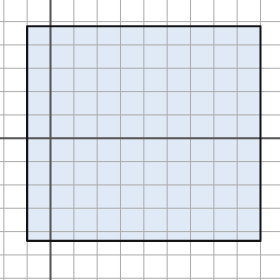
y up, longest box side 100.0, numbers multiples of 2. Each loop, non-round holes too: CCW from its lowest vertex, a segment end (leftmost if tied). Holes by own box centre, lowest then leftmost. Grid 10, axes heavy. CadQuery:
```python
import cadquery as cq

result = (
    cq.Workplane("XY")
    .moveTo(-10.0, -44.0)
    .lineTo(90.0, -44.0)
    .lineTo(90.0, 48.0)
    .lineTo(-10.0, 48.0)
    .close()
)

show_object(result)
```